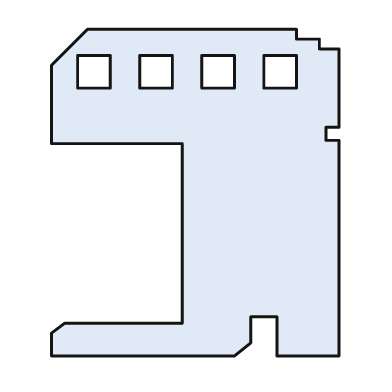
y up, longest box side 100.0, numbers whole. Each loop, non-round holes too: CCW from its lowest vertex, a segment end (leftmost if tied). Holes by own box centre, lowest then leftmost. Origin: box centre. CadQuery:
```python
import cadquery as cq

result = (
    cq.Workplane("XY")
    .moveTo(-44.0, -50.0)
    .lineTo(12.0, -50.0)
    .lineTo(17.0, -46.0)
    .lineTo(17.0, -38.0)
    .lineTo(25.0, -38.0)
    .lineTo(25.0, -50.0)
    .lineTo(44.0, -50.0)
    .lineTo(44.0, 16.0)
    .lineTo(40.0, 16.0)
    .lineTo(40.0, 20.0)
    .lineTo(44.0, 20.0)
    .lineTo(44.0, 44.0)
    .lineTo(38.0, 44.0)
    .lineTo(38.0, 47.0)
    .lineTo(31.0, 47.0)
    .lineTo(31.0, 50.0)
    .lineTo(-33.0, 50.0)
    .lineTo(-44.0, 39.0)
    .lineTo(-44.0, 15.0)
    .lineTo(-4.0, 15.0)
    .lineTo(-4.0, -40.0)
    .lineTo(-40.0, -40.0)
    .lineTo(-44.0, -43.0)
    .close()
    .moveTo(-36.0, 32.0)
    .lineTo(-26.0, 32.0)
    .lineTo(-26.0, 42.0)
    .lineTo(-36.0, 42.0)
    .close()
    .moveTo(-17.0, 32.0)
    .lineTo(-7.0, 32.0)
    .lineTo(-7.0, 42.0)
    .lineTo(-17.0, 42.0)
    .close()
    .moveTo(2.0, 32.0)
    .lineTo(12.0, 32.0)
    .lineTo(12.0, 42.0)
    .lineTo(2.0, 42.0)
    .close()
    .moveTo(21.0, 32.0)
    .lineTo(31.0, 32.0)
    .lineTo(31.0, 42.0)
    .lineTo(21.0, 42.0)
    .close()
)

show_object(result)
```